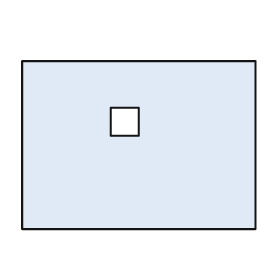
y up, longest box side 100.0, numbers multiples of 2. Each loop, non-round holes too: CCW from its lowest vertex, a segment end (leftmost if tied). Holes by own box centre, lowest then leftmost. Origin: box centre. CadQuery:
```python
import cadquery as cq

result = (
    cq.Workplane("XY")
    .moveTo(-50.0, -36.0)
    .lineTo(50.0, -36.0)
    .lineTo(50.0, 36.0)
    .lineTo(-50.0, 36.0)
    .close()
    .moveTo(-12.0, 4.0)
    .lineTo(0.0, 4.0)
    .lineTo(0.0, 16.0)
    .lineTo(-12.0, 16.0)
    .close()
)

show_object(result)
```